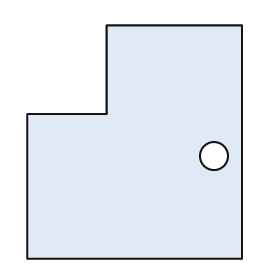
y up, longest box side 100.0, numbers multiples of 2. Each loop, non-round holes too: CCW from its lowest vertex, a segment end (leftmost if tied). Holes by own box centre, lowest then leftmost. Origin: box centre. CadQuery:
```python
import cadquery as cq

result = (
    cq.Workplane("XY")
    .moveTo(-46.0, -50.0)
    .lineTo(46.0, -50.0)
    .lineTo(46.0, 50.0)
    .lineTo(-12.0, 50.0)
    .lineTo(-12.0, 12.0)
    .lineTo(-46.0, 12.0)
    .close()
    .moveTo(34.0, -6.0)
    .circle(6.0)
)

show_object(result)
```